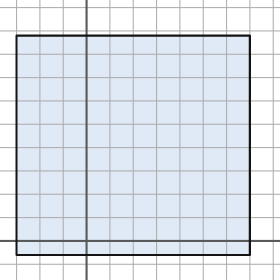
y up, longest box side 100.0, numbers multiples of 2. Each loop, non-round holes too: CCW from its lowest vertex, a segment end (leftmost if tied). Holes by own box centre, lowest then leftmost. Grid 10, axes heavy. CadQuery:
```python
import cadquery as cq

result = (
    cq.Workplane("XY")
    .moveTo(-30.0, -6.0)
    .lineTo(70.0, -6.0)
    .lineTo(70.0, 88.0)
    .lineTo(-30.0, 88.0)
    .close()
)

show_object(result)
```